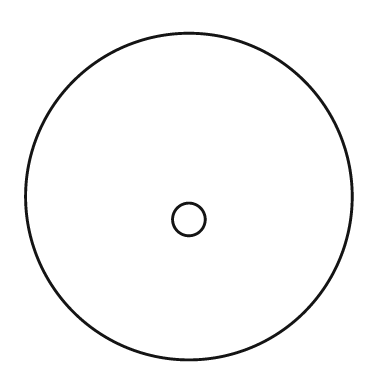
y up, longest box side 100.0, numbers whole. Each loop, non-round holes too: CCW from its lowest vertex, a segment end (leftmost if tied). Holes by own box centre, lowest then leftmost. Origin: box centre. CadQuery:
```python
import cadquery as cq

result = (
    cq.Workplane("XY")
    .moveTo(0.0, 0.0)
    .circle(50.0)
    .moveTo(0.0, -7.0)
    .circle(5.0)
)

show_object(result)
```